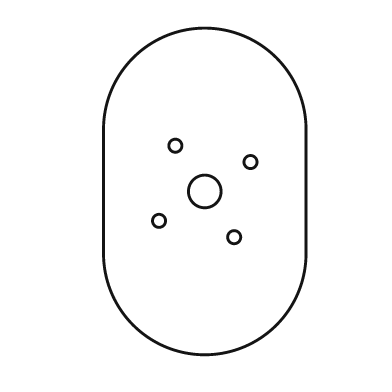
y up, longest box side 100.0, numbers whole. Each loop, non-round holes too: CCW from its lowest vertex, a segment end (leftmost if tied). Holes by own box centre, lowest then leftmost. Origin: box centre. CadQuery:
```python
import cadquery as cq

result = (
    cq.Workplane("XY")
    .moveTo(-31.0, -19.0)
    .threePointArc((0.0, -50.0), (31.0, -19.0))
    .lineTo(31.0, 19.0)
    .threePointArc((0.0, 50.0), (-31.0, 19.0))
    .close()
    .moveTo(9.0, -14.0)
    .circle(2.0)
    .moveTo(-14.0, -9.0)
    .circle(2.0)
    .moveTo(0.0, 0.0)
    .circle(5.0)
    .moveTo(14.0, 9.0)
    .circle(2.0)
    .moveTo(-9.0, 14.0)
    .circle(2.0)
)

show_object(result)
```